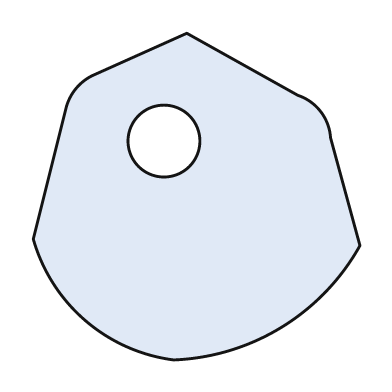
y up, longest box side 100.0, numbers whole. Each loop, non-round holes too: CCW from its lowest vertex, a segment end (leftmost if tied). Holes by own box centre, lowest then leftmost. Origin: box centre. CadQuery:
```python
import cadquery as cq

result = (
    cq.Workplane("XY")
    .moveTo(-7.0, -50.0)
    .threePointArc((26.0, -40.0), (50.0, -15.0))
    .lineTo(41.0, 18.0)
    .threePointArc((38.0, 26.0), (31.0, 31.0))
    .lineTo(-3.0, 50.0)
    .lineTo(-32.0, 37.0)
    .threePointArc((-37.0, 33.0), (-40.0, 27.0))
    .lineTo(-50.0, -13.0)
    .threePointArc((-34.0, -38.0), (-7.0, -50.0))
    .close()
    .moveTo(-10.0, 17.0)
    .circle(11.0)
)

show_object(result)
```